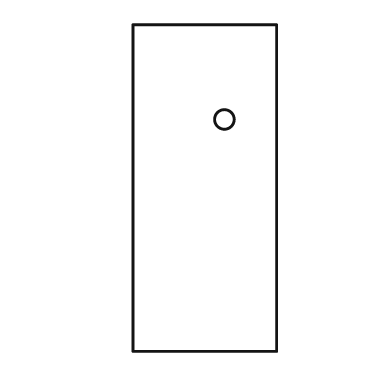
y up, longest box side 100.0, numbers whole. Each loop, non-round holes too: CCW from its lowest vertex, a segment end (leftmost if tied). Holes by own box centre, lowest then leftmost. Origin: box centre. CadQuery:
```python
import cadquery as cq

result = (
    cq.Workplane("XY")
    .moveTo(-22.0, -50.0)
    .lineTo(22.0, -50.0)
    .lineTo(22.0, 50.0)
    .lineTo(-22.0, 50.0)
    .close()
    .moveTo(6.0, 21.0)
    .circle(3.0)
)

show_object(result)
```